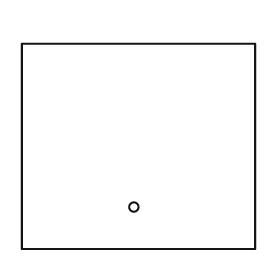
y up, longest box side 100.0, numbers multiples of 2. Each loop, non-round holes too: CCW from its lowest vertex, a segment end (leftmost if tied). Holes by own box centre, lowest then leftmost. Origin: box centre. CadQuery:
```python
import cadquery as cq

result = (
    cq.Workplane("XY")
    .moveTo(-50.0, -44.0)
    .lineTo(50.0, -44.0)
    .lineTo(50.0, 44.0)
    .lineTo(-50.0, 44.0)
    .close()
    .moveTo(-2.0, -26.0)
    .circle(2.0)
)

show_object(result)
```